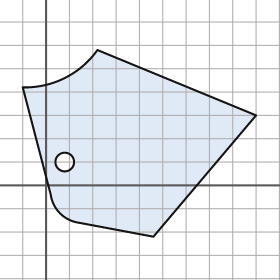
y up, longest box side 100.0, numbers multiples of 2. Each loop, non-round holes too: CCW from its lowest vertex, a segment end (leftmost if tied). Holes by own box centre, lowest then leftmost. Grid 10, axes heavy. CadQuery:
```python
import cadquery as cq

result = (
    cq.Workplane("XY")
    .moveTo(46.0, -22.0)
    .lineTo(90.0, 30.0)
    .lineTo(22.0, 58.0)
    .threePointArc((8.0, 46.0), (-10.0, 42.0))
    .lineTo(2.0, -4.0)
    .threePointArc((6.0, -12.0), (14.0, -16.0))
    .close()
    .moveTo(8.0, 10.0)
    .circle(4.0)
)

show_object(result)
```